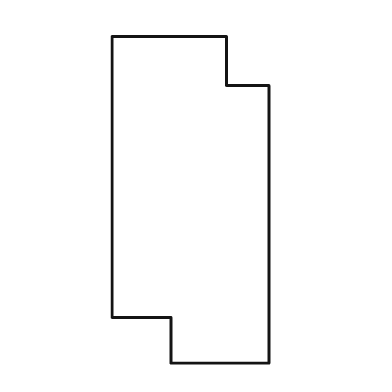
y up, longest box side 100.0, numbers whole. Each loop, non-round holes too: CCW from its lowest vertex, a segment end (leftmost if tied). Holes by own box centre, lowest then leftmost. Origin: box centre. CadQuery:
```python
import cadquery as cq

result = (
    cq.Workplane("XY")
    .moveTo(-6.0, -50.0)
    .lineTo(24.0, -50.0)
    .lineTo(24.0, 35.0)
    .lineTo(11.0, 35.0)
    .lineTo(11.0, 50.0)
    .lineTo(-24.0, 50.0)
    .lineTo(-24.0, -36.0)
    .lineTo(-6.0, -36.0)
    .close()
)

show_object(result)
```